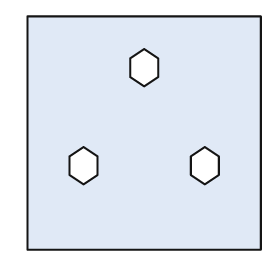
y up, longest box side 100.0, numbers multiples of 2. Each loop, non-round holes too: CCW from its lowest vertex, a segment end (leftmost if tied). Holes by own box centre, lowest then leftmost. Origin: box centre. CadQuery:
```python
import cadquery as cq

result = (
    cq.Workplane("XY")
    .moveTo(-50.0, -50.0)
    .lineTo(50.0, -50.0)
    .lineTo(50.0, 50.0)
    .lineTo(-50.0, 50.0)
    .close()
    .moveTo(-26.0, -22.0)
    .lineTo(-20.0, -18.0)
    .lineTo(-20.0, -10.0)
    .lineTo(-26.0, -6.0)
    .lineTo(-32.0, -10.0)
    .lineTo(-32.0, -18.0)
    .close()
    .moveTo(26.0, -22.0)
    .lineTo(32.0, -18.0)
    .lineTo(32.0, -10.0)
    .lineTo(26.0, -6.0)
    .lineTo(20.0, -10.0)
    .lineTo(20.0, -18.0)
    .close()
    .moveTo(0.0, 20.0)
    .lineTo(6.0, 24.0)
    .lineTo(6.0, 32.0)
    .lineTo(0.0, 36.0)
    .lineTo(-6.0, 32.0)
    .lineTo(-6.0, 24.0)
    .close()
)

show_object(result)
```